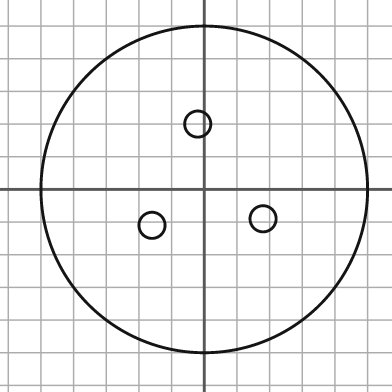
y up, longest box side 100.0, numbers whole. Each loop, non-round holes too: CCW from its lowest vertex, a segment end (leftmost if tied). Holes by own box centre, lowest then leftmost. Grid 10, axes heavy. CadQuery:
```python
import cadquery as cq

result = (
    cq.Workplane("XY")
    .moveTo(0.0, 0.0)
    .circle(50.0)
    .moveTo(-16.0, -11.0)
    .circle(4.0)
    .moveTo(18.0, -9.0)
    .circle(4.0)
    .moveTo(-2.0, 20.0)
    .circle(4.0)
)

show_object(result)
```